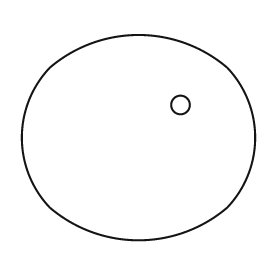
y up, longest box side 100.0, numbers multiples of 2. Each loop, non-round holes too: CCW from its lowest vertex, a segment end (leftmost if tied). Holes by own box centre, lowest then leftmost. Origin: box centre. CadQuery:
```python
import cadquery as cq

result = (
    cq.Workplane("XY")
    .moveTo(-38.0, -30.0)
    .threePointArc((0.0, -44.0), (38.0, -30.0))
    .threePointArc((50.0, 0.0), (38.0, 30.0))
    .threePointArc((0.0, 44.0), (-38.0, 30.0))
    .threePointArc((-50.0, 0.0), (-38.0, -30.0))
    .close()
    .moveTo(18.0, 14.0)
    .circle(4.0)
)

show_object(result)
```